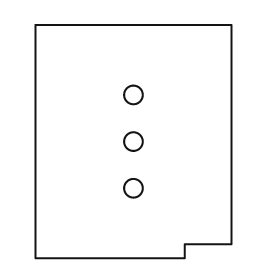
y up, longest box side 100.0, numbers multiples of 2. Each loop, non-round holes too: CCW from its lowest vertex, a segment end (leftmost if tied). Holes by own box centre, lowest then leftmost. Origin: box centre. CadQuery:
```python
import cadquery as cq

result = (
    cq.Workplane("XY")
    .moveTo(-42.0, -50.0)
    .lineTo(22.0, -50.0)
    .lineTo(22.0, -44.0)
    .lineTo(42.0, -44.0)
    .lineTo(42.0, 50.0)
    .lineTo(-42.0, 50.0)
    .close()
    .moveTo(0.0, -20.0)
    .circle(4.0)
    .moveTo(0.0, 0.0)
    .circle(4.0)
    .moveTo(0.0, 20.0)
    .circle(4.0)
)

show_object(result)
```